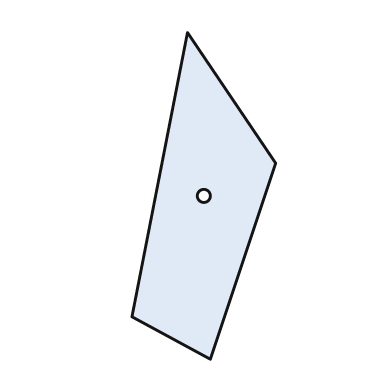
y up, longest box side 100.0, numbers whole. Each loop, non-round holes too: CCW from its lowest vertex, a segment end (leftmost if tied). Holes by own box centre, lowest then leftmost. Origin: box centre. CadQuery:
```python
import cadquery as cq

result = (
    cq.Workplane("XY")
    .moveTo(2.0, -50.0)
    .lineTo(22.0, 10.0)
    .lineTo(-5.0, 50.0)
    .lineTo(-22.0, -37.0)
    .close()
    .moveTo(0.0, 0.0)
    .circle(2.0)
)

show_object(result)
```